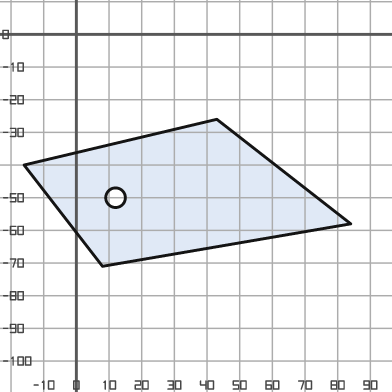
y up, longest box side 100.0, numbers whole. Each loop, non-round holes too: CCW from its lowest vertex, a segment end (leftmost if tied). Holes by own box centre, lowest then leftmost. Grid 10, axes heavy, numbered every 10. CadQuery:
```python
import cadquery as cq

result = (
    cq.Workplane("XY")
    .moveTo(8.0, -71.0)
    .lineTo(84.0, -58.0)
    .lineTo(43.0, -26.0)
    .lineTo(-16.0, -40.0)
    .close()
    .moveTo(12.0, -50.0)
    .circle(3.0)
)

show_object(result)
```